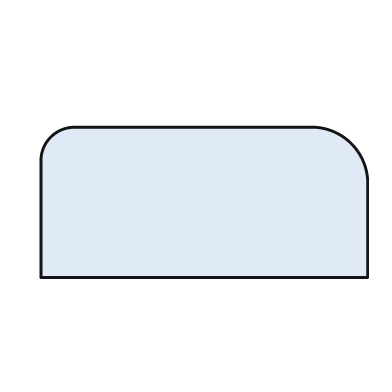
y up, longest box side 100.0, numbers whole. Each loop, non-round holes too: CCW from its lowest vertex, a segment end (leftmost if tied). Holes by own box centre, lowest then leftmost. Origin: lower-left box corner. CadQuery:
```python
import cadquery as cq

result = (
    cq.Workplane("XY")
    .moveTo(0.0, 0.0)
    .lineTo(100.0, 0.0)
    .lineTo(100.0, 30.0)
    .threePointArc((95.0, 41.0), (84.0, 46.0))
    .lineTo(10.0, 46.0)
    .threePointArc((3.0, 43.0), (0.0, 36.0))
    .close()
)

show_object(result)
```